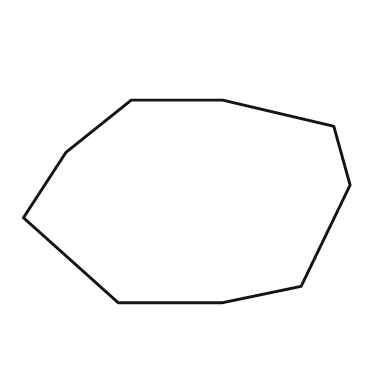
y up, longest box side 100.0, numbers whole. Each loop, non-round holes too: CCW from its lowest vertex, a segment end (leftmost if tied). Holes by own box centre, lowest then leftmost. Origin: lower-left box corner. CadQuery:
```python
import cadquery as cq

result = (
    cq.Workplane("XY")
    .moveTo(29.0, 0.0)
    .lineTo(61.0, 0.0)
    .lineTo(85.0, 5.0)
    .lineTo(100.0, 36.0)
    .lineTo(95.0, 54.0)
    .lineTo(61.0, 62.0)
    .lineTo(33.0, 62.0)
    .lineTo(13.0, 46.0)
    .lineTo(0.0, 26.0)
    .close()
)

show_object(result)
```